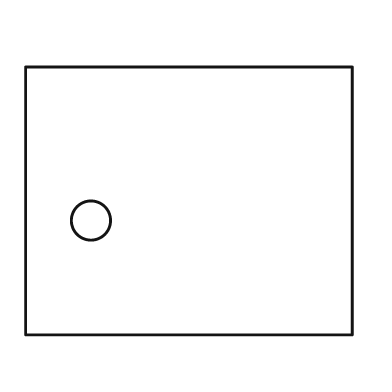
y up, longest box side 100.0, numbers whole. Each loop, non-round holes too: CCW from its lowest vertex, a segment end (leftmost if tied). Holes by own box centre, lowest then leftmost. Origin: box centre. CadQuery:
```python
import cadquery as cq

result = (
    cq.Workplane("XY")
    .moveTo(-50.0, -41.0)
    .lineTo(50.0, -41.0)
    .lineTo(50.0, 41.0)
    .lineTo(-50.0, 41.0)
    .close()
    .moveTo(-30.0, -6.0)
    .circle(6.0)
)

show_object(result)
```